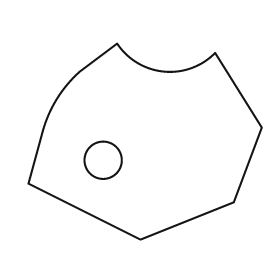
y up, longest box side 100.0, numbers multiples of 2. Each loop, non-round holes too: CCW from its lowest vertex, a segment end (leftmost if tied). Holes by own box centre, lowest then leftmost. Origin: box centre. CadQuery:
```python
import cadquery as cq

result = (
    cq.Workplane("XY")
    .moveTo(-2.0, -42.0)
    .lineTo(38.0, -26.0)
    .lineTo(50.0, 6.0)
    .lineTo(30.0, 38.0)
    .threePointArc((8.0, 30.0), (-12.0, 42.0))
    .lineTo(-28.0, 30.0)
    .threePointArc((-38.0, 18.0), (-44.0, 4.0))
    .lineTo(-50.0, -18.0)
    .close()
    .moveTo(-18.0, -8.0)
    .circle(8.0)
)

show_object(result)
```